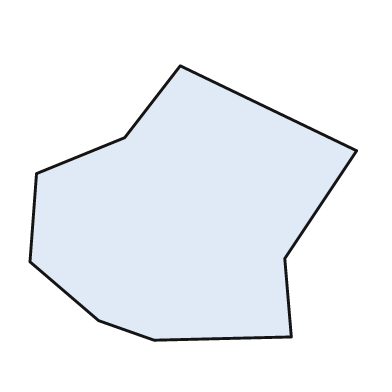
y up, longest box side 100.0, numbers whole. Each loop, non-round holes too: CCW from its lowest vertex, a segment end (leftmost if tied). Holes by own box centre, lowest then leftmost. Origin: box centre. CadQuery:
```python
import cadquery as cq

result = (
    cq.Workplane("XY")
    .moveTo(-12.0, -42.0)
    .lineTo(30.0, -41.0)
    .lineTo(28.0, -17.0)
    .lineTo(50.0, 16.0)
    .lineTo(-4.0, 42.0)
    .lineTo(-21.0, 20.0)
    .lineTo(-48.0, 9.0)
    .lineTo(-50.0, -18.0)
    .lineTo(-29.0, -36.0)
    .close()
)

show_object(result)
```